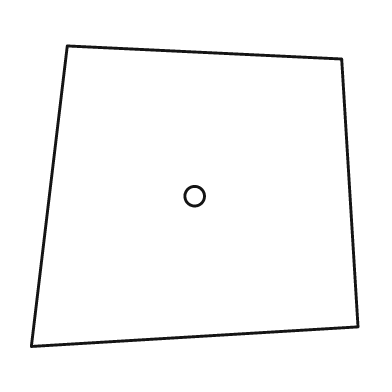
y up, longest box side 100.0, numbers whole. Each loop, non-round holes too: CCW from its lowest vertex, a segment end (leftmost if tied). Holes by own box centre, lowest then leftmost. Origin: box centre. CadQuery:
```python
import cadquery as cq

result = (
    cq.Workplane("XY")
    .moveTo(-50.0, -46.0)
    .lineTo(50.0, -40.0)
    .lineTo(45.0, 42.0)
    .lineTo(-39.0, 46.0)
    .close()
    .moveTo(0.0, 0.0)
    .circle(3.0)
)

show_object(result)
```